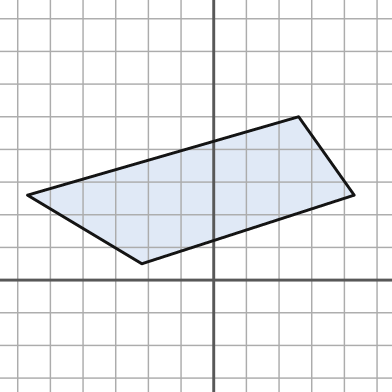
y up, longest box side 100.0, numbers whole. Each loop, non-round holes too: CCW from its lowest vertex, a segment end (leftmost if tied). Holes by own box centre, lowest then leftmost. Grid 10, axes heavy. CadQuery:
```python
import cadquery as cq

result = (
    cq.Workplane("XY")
    .moveTo(-22.0, 5.0)
    .lineTo(43.0, 26.0)
    .lineTo(26.0, 50.0)
    .lineTo(-57.0, 26.0)
    .close()
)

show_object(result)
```